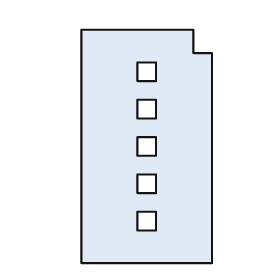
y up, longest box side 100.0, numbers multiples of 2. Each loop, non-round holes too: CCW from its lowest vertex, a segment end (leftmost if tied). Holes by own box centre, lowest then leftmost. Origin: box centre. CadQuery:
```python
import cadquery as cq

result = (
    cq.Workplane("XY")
    .moveTo(-28.0, -50.0)
    .lineTo(28.0, -50.0)
    .lineTo(28.0, 40.0)
    .lineTo(20.0, 40.0)
    .lineTo(20.0, 50.0)
    .lineTo(-28.0, 50.0)
    .close()
    .moveTo(-4.0, -36.0)
    .lineTo(4.0, -36.0)
    .lineTo(4.0, -28.0)
    .lineTo(-4.0, -28.0)
    .close()
    .moveTo(-4.0, -20.0)
    .lineTo(4.0, -20.0)
    .lineTo(4.0, -12.0)
    .lineTo(-4.0, -12.0)
    .close()
    .moveTo(-4.0, -4.0)
    .lineTo(4.0, -4.0)
    .lineTo(4.0, 4.0)
    .lineTo(-4.0, 4.0)
    .close()
    .moveTo(-4.0, 12.0)
    .lineTo(4.0, 12.0)
    .lineTo(4.0, 20.0)
    .lineTo(-4.0, 20.0)
    .close()
    .moveTo(-4.0, 28.0)
    .lineTo(4.0, 28.0)
    .lineTo(4.0, 36.0)
    .lineTo(-4.0, 36.0)
    .close()
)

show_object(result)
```